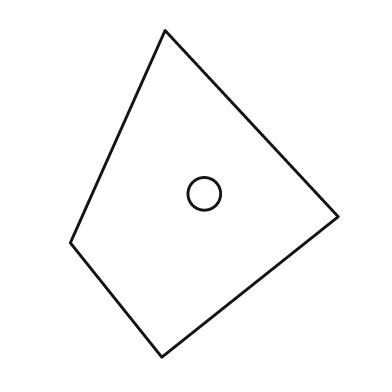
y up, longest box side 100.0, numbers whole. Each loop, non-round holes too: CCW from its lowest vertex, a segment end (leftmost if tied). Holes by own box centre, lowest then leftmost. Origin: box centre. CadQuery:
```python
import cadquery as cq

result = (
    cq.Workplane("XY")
    .moveTo(-13.0, -50.0)
    .lineTo(41.0, -7.0)
    .lineTo(-12.0, 50.0)
    .lineTo(-41.0, -15.0)
    .close()
    .moveTo(0.0, 0.0)
    .circle(5.0)
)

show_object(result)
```